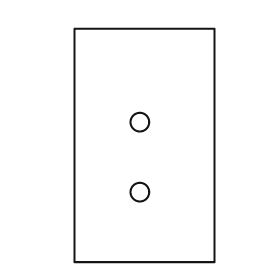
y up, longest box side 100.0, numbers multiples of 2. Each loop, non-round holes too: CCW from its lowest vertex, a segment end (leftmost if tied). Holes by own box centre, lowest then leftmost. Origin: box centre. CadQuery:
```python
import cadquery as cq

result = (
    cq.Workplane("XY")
    .moveTo(-30.0, -50.0)
    .lineTo(30.0, -50.0)
    .lineTo(30.0, 50.0)
    .lineTo(-30.0, 50.0)
    .close()
    .moveTo(-2.0, -20.0)
    .circle(4.0)
    .moveTo(-2.0, 10.0)
    .circle(4.0)
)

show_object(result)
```